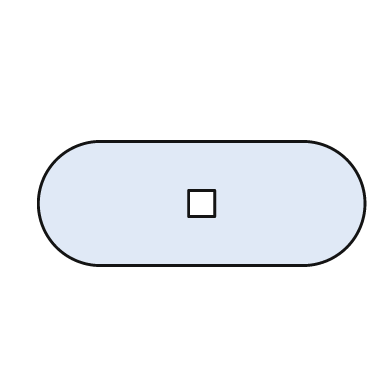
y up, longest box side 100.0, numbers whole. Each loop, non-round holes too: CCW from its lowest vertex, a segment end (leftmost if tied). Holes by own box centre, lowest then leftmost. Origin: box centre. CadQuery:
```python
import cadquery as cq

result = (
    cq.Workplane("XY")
    .moveTo(-31.0, -19.0)
    .lineTo(31.0, -19.0)
    .threePointArc((50.0, 0.0), (31.0, 19.0))
    .lineTo(-31.0, 19.0)
    .threePointArc((-50.0, 0.0), (-31.0, -19.0))
    .close()
    .moveTo(-4.0, -4.0)
    .lineTo(4.0, -4.0)
    .lineTo(4.0, 4.0)
    .lineTo(-4.0, 4.0)
    .close()
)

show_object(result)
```